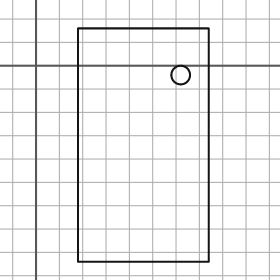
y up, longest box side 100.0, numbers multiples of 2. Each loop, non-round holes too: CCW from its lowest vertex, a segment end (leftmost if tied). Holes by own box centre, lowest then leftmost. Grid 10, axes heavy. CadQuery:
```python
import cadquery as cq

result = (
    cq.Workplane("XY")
    .moveTo(18.0, -84.0)
    .lineTo(74.0, -84.0)
    .lineTo(74.0, 16.0)
    .lineTo(18.0, 16.0)
    .close()
    .moveTo(62.0, -4.0)
    .circle(4.0)
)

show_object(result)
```